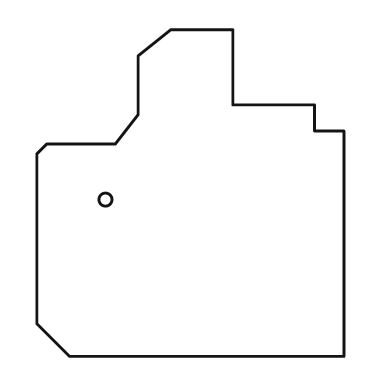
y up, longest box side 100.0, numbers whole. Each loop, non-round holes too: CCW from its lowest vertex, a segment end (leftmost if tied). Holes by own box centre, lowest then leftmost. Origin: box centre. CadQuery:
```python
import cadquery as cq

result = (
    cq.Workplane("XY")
    .moveTo(-37.0, -50.0)
    .lineTo(47.0, -50.0)
    .lineTo(47.0, 19.0)
    .lineTo(38.0, 19.0)
    .lineTo(38.0, 27.0)
    .lineTo(13.0, 27.0)
    .lineTo(13.0, 50.0)
    .lineTo(-6.0, 50.0)
    .lineTo(-16.0, 42.0)
    .lineTo(-16.0, 24.0)
    .lineTo(-23.0, 15.0)
    .lineTo(-44.0, 15.0)
    .lineTo(-47.0, 12.0)
    .lineTo(-47.0, -40.0)
    .close()
    .moveTo(-26.0, -2.0)
    .circle(2.0)
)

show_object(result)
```